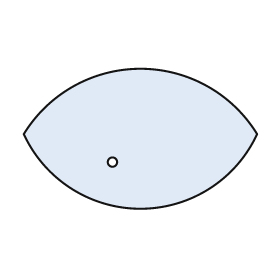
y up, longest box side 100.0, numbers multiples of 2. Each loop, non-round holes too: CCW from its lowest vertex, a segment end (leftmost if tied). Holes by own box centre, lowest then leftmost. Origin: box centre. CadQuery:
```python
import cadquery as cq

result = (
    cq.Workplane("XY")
    .moveTo(-50.0, 2.0)
    .threePointArc((0.0, -30.0), (50.0, 2.0))
    .threePointArc((0.0, 30.0), (-50.0, 2.0))
    .close()
    .moveTo(-12.0, -10.0)
    .circle(2.0)
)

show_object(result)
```